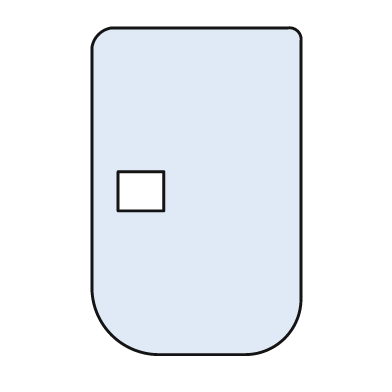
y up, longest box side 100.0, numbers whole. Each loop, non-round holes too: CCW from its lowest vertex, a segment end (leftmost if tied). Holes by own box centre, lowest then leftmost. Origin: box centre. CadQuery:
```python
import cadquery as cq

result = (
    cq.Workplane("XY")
    .moveTo(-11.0, -50.0)
    .lineTo(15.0, -50.0)
    .threePointArc((27.0, -45.0), (32.0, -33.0))
    .lineTo(32.0, 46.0)
    .threePointArc((31.0, 49.0), (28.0, 50.0))
    .lineTo(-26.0, 50.0)
    .threePointArc((-30.0, 48.0), (-32.0, 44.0))
    .lineTo(-32.0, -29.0)
    .threePointArc((-26.0, -44.0), (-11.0, -50.0))
    .close()
    .moveTo(-24.0, -6.0)
    .lineTo(-10.0, -6.0)
    .lineTo(-10.0, 6.0)
    .lineTo(-24.0, 6.0)
    .close()
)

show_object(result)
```